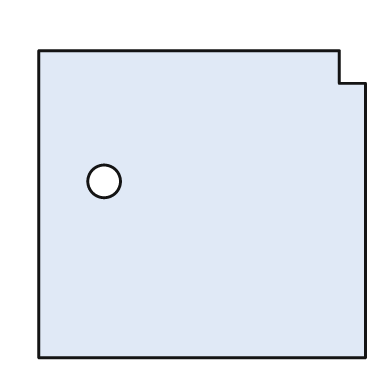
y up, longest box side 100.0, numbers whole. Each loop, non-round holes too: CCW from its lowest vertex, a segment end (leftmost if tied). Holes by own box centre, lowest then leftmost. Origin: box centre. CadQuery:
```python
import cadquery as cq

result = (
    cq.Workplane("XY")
    .moveTo(-50.0, -47.0)
    .lineTo(50.0, -47.0)
    .lineTo(50.0, 37.0)
    .lineTo(42.0, 37.0)
    .lineTo(42.0, 47.0)
    .lineTo(-50.0, 47.0)
    .close()
    .moveTo(-30.0, 7.0)
    .circle(5.0)
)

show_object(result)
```